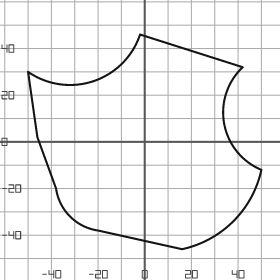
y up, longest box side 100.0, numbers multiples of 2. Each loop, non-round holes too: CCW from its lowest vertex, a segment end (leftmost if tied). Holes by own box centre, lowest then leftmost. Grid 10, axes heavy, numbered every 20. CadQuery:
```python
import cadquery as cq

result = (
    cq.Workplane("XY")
    .moveTo(16.0, -46.0)
    .threePointArc((38.0, -34.0), (50.0, -12.0))
    .threePointArc((34.0, 8.0), (42.0, 32.0))
    .lineTo(-2.0, 46.0)
    .threePointArc((-22.0, 26.0), (-50.0, 30.0))
    .lineTo(-46.0, 2.0)
    .lineTo(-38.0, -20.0)
    .threePointArc((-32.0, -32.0), (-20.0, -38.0))
    .close()
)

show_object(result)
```